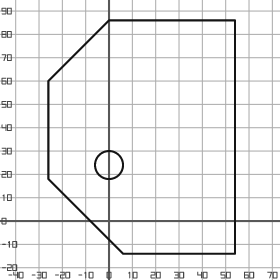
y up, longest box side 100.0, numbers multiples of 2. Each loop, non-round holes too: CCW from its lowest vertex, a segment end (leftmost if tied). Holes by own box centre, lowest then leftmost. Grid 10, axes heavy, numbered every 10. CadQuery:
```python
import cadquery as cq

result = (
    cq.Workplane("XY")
    .moveTo(6.0, -14.0)
    .lineTo(54.0, -14.0)
    .lineTo(54.0, 86.0)
    .lineTo(0.0, 86.0)
    .lineTo(-26.0, 60.0)
    .lineTo(-26.0, 18.0)
    .close()
    .moveTo(0.0, 24.0)
    .circle(6.0)
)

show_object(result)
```